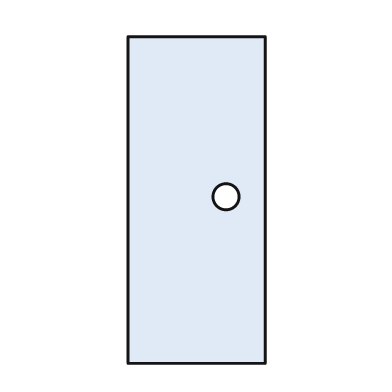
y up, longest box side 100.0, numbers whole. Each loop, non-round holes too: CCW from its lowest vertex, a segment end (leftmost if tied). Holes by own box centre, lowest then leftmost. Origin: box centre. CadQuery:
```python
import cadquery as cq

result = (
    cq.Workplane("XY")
    .moveTo(-21.0, -50.0)
    .lineTo(21.0, -50.0)
    .lineTo(21.0, 50.0)
    .lineTo(-21.0, 50.0)
    .close()
    .moveTo(9.0, 1.0)
    .circle(4.0)
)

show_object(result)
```